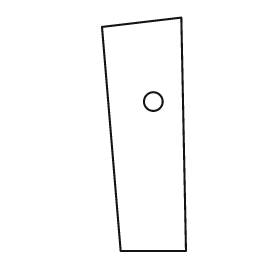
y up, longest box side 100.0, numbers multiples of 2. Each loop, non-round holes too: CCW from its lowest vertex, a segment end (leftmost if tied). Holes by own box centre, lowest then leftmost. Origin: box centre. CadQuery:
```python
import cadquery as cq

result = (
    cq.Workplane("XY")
    .moveTo(-10.0, -50.0)
    .lineTo(18.0, -50.0)
    .lineTo(16.0, 50.0)
    .lineTo(-18.0, 46.0)
    .close()
    .moveTo(4.0, 14.0)
    .circle(4.0)
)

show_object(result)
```